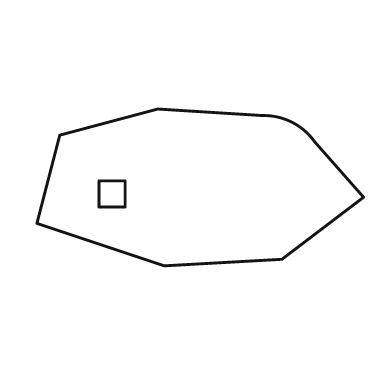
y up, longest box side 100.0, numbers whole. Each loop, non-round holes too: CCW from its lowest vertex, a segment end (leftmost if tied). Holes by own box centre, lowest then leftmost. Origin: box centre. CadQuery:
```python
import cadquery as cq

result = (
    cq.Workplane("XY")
    .moveTo(-11.0, -24.0)
    .lineTo(25.0, -22.0)
    .lineTo(50.0, -3.0)
    .lineTo(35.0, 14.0)
    .threePointArc((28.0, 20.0), (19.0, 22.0))
    .lineTo(-13.0, 24.0)
    .lineTo(-43.0, 16.0)
    .lineTo(-50.0, -11.0)
    .close()
    .moveTo(-31.0, -6.0)
    .lineTo(-23.0, -6.0)
    .lineTo(-23.0, 2.0)
    .lineTo(-31.0, 2.0)
    .close()
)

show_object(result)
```